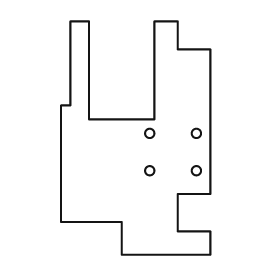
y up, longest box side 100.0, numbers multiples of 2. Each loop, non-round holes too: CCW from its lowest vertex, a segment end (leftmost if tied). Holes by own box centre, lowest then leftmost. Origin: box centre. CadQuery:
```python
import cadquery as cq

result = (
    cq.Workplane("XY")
    .moveTo(-6.0, -50.0)
    .lineTo(32.0, -50.0)
    .lineTo(32.0, -40.0)
    .lineTo(18.0, -40.0)
    .lineTo(18.0, -24.0)
    .lineTo(32.0, -24.0)
    .lineTo(32.0, 38.0)
    .lineTo(18.0, 38.0)
    .lineTo(18.0, 50.0)
    .lineTo(8.0, 50.0)
    .lineTo(8.0, 8.0)
    .lineTo(-20.0, 8.0)
    .lineTo(-20.0, 50.0)
    .lineTo(-28.0, 50.0)
    .lineTo(-28.0, 14.0)
    .lineTo(-32.0, 14.0)
    .lineTo(-32.0, -36.0)
    .lineTo(-6.0, -36.0)
    .close()
    .moveTo(6.0, -14.0)
    .circle(2.0)
    .moveTo(26.0, -14.0)
    .circle(2.0)
    .moveTo(6.0, 2.0)
    .circle(2.0)
    .moveTo(26.0, 2.0)
    .circle(2.0)
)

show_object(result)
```